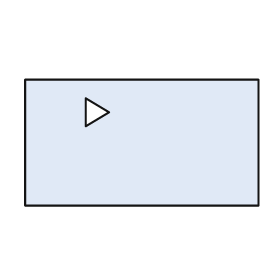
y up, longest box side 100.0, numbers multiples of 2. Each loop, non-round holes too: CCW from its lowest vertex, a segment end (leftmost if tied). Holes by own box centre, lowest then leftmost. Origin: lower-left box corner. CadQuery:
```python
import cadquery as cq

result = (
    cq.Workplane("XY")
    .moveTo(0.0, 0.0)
    .lineTo(100.0, 0.0)
    .lineTo(100.0, 54.0)
    .lineTo(0.0, 54.0)
    .close()
    .moveTo(26.0, 34.0)
    .lineTo(36.0, 40.0)
    .lineTo(26.0, 46.0)
    .close()
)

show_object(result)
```